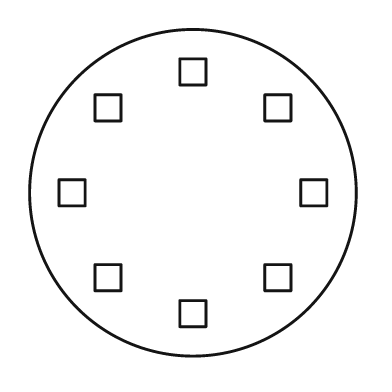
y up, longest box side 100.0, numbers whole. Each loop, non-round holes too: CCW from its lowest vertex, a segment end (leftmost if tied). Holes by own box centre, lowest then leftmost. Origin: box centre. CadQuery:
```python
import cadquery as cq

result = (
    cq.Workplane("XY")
    .moveTo(0.0, 0.0)
    .circle(50.0)
    .moveTo(-4.0, -41.0)
    .lineTo(4.0, -41.0)
    .lineTo(4.0, -33.0)
    .lineTo(-4.0, -33.0)
    .close()
    .moveTo(-30.0, -30.0)
    .lineTo(-22.0, -30.0)
    .lineTo(-22.0, -22.0)
    .lineTo(-30.0, -22.0)
    .close()
    .moveTo(22.0, -30.0)
    .lineTo(30.0, -30.0)
    .lineTo(30.0, -22.0)
    .lineTo(22.0, -22.0)
    .close()
    .moveTo(-41.0, -4.0)
    .lineTo(-33.0, -4.0)
    .lineTo(-33.0, 4.0)
    .lineTo(-41.0, 4.0)
    .close()
    .moveTo(33.0, -4.0)
    .lineTo(41.0, -4.0)
    .lineTo(41.0, 4.0)
    .lineTo(33.0, 4.0)
    .close()
    .moveTo(-30.0, 22.0)
    .lineTo(-22.0, 22.0)
    .lineTo(-22.0, 30.0)
    .lineTo(-30.0, 30.0)
    .close()
    .moveTo(22.0, 22.0)
    .lineTo(30.0, 22.0)
    .lineTo(30.0, 30.0)
    .lineTo(22.0, 30.0)
    .close()
    .moveTo(-4.0, 33.0)
    .lineTo(4.0, 33.0)
    .lineTo(4.0, 41.0)
    .lineTo(-4.0, 41.0)
    .close()
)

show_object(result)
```